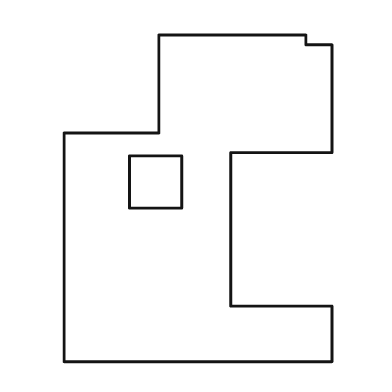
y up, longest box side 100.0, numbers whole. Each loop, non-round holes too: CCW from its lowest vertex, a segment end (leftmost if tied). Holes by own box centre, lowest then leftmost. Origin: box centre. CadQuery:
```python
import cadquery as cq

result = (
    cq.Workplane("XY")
    .moveTo(-41.0, -50.0)
    .lineTo(41.0, -50.0)
    .lineTo(41.0, -33.0)
    .lineTo(10.0, -33.0)
    .lineTo(10.0, 14.0)
    .lineTo(41.0, 14.0)
    .lineTo(41.0, 47.0)
    .lineTo(33.0, 47.0)
    .lineTo(33.0, 50.0)
    .lineTo(-12.0, 50.0)
    .lineTo(-12.0, 20.0)
    .lineTo(-41.0, 20.0)
    .close()
    .moveTo(-21.0, -3.0)
    .lineTo(-5.0, -3.0)
    .lineTo(-5.0, 13.0)
    .lineTo(-21.0, 13.0)
    .close()
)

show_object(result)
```